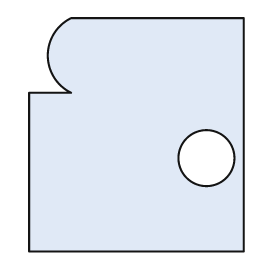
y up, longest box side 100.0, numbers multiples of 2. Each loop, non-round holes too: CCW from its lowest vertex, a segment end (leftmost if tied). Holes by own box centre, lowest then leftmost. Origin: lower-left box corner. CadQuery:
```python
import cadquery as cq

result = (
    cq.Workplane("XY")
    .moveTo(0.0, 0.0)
    .lineTo(92.0, 0.0)
    .lineTo(92.0, 100.0)
    .lineTo(18.0, 100.0)
    .threePointArc((8.0, 84.0), (18.0, 68.0))
    .lineTo(0.0, 68.0)
    .close()
    .moveTo(76.0, 40.0)
    .circle(12.0)
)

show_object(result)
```